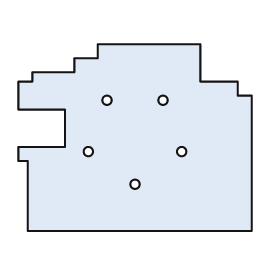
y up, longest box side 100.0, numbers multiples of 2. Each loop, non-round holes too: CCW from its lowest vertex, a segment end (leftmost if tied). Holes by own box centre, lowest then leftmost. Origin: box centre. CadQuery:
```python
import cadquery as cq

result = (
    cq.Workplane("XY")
    .moveTo(-46.0, -40.0)
    .lineTo(50.0, -40.0)
    .lineTo(50.0, 18.0)
    .lineTo(44.0, 18.0)
    .lineTo(44.0, 24.0)
    .lineTo(28.0, 24.0)
    .lineTo(28.0, 40.0)
    .lineTo(-16.0, 40.0)
    .lineTo(-16.0, 34.0)
    .lineTo(-26.0, 34.0)
    .lineTo(-26.0, 28.0)
    .lineTo(-44.0, 28.0)
    .lineTo(-44.0, 24.0)
    .lineTo(-50.0, 24.0)
    .lineTo(-50.0, 12.0)
    .lineTo(-30.0, 12.0)
    .lineTo(-30.0, -4.0)
    .lineTo(-50.0, -4.0)
    .lineTo(-50.0, -10.0)
    .lineTo(-46.0, -10.0)
    .close()
    .moveTo(0.0, -20.0)
    .circle(2.0)
    .moveTo(-20.0, -6.0)
    .circle(2.0)
    .moveTo(20.0, -6.0)
    .circle(2.0)
    .moveTo(-12.0, 16.0)
    .circle(2.0)
    .moveTo(12.0, 16.0)
    .circle(2.0)
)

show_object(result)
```